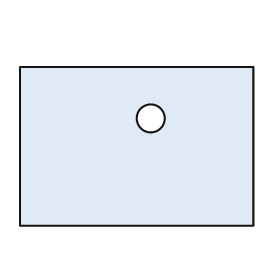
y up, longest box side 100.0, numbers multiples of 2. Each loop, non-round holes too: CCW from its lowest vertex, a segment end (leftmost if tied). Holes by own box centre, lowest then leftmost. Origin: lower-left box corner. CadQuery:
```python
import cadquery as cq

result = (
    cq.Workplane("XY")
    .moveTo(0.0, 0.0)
    .lineTo(100.0, 0.0)
    .lineTo(100.0, 68.0)
    .lineTo(0.0, 68.0)
    .close()
    .moveTo(56.0, 46.0)
    .circle(6.0)
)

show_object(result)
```